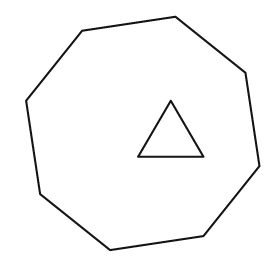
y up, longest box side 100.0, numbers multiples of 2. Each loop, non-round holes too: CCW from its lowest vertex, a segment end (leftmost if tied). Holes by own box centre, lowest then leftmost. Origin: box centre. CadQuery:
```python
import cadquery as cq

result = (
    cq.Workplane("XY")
    .moveTo(-14.0, -50.0)
    .lineTo(26.0, -44.0)
    .lineTo(50.0, -14.0)
    .lineTo(44.0, 26.0)
    .lineTo(14.0, 50.0)
    .lineTo(-26.0, 44.0)
    .lineTo(-50.0, 14.0)
    .lineTo(-44.0, -26.0)
    .close()
    .moveTo(-2.0, -10.0)
    .lineTo(26.0, -10.0)
    .lineTo(12.0, 14.0)
    .close()
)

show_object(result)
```